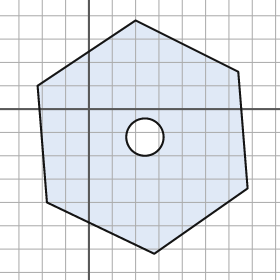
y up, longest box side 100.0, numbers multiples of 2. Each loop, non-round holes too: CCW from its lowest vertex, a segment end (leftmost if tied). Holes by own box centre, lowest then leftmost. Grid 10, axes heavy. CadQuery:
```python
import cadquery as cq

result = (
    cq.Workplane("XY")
    .moveTo(28.0, -62.0)
    .lineTo(68.0, -34.0)
    .lineTo(64.0, 16.0)
    .lineTo(20.0, 38.0)
    .lineTo(-22.0, 10.0)
    .lineTo(-18.0, -40.0)
    .close()
    .moveTo(24.0, -12.0)
    .circle(8.0)
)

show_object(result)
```